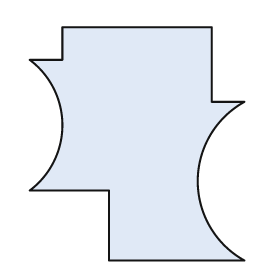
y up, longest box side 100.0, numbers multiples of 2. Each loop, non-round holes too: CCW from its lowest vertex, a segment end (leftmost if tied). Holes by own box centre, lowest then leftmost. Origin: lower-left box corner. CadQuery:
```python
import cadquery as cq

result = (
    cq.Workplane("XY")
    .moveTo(34.0, 0.0)
    .lineTo(92.0, 0.0)
    .threePointArc((72.0, 34.0), (92.0, 68.0))
    .lineTo(78.0, 68.0)
    .lineTo(78.0, 100.0)
    .lineTo(14.0, 100.0)
    .lineTo(14.0, 86.0)
    .lineTo(0.0, 86.0)
    .threePointArc((14.0, 58.0), (0.0, 30.0))
    .lineTo(34.0, 30.0)
    .close()
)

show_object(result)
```